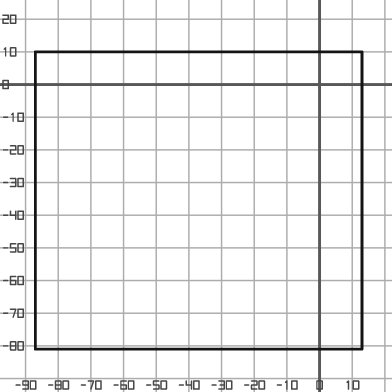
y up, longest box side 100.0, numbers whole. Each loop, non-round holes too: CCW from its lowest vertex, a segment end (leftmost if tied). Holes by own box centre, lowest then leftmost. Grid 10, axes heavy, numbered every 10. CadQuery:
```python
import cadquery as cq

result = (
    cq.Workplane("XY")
    .moveTo(-87.0, -81.0)
    .lineTo(13.0, -81.0)
    .lineTo(13.0, 10.0)
    .lineTo(-87.0, 10.0)
    .close()
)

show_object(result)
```